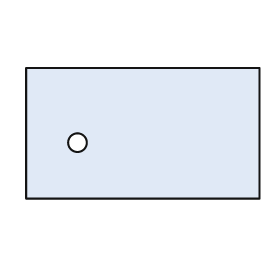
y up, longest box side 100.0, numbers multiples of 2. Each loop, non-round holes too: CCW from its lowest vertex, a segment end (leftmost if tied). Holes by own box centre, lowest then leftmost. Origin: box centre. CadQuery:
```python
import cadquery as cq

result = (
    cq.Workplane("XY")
    .moveTo(-50.0, -28.0)
    .lineTo(50.0, -28.0)
    .lineTo(50.0, 28.0)
    .lineTo(-50.0, 28.0)
    .close()
    .moveTo(-28.0, -4.0)
    .circle(4.0)
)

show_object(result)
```